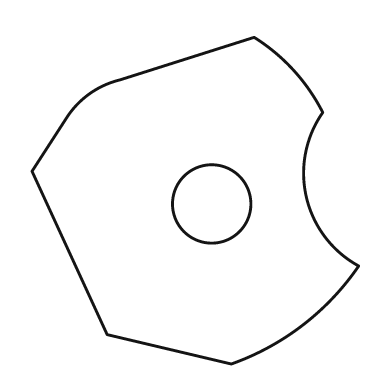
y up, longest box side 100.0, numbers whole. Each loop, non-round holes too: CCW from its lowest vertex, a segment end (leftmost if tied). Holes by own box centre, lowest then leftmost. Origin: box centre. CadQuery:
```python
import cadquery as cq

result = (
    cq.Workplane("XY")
    .moveTo(11.0, -50.0)
    .threePointArc((33.0, -38.0), (50.0, -20.0))
    .threePointArc((34.0, 1.0), (39.0, 27.0))
    .threePointArc((30.0, 40.0), (18.0, 50.0))
    .lineTo(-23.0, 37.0)
    .threePointArc((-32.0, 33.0), (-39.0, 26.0))
    .lineTo(-50.0, 9.0)
    .lineTo(-27.0, -41.0)
    .close()
    .moveTo(5.0, -1.0)
    .circle(12.0)
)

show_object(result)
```